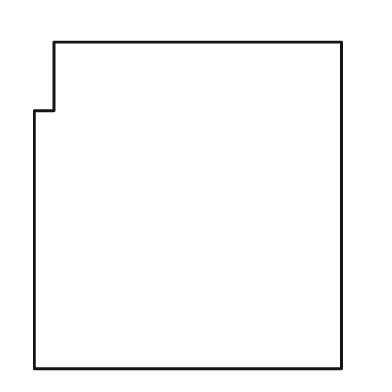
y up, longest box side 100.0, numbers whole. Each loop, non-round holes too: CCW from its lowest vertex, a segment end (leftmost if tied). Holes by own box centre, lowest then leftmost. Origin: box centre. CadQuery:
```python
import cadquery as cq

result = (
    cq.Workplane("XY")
    .moveTo(-47.0, -50.0)
    .lineTo(47.0, -50.0)
    .lineTo(47.0, 50.0)
    .lineTo(-41.0, 50.0)
    .lineTo(-41.0, 29.0)
    .lineTo(-47.0, 29.0)
    .close()
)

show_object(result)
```